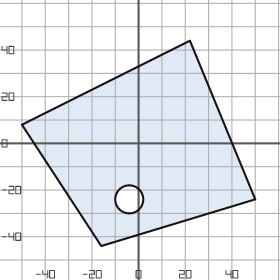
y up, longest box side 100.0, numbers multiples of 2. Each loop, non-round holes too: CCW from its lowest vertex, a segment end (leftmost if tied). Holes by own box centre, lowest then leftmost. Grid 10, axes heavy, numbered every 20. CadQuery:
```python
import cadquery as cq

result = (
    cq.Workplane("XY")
    .moveTo(-16.0, -44.0)
    .lineTo(50.0, -24.0)
    .lineTo(22.0, 44.0)
    .lineTo(-50.0, 8.0)
    .close()
    .moveTo(-4.0, -24.0)
    .circle(6.0)
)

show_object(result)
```